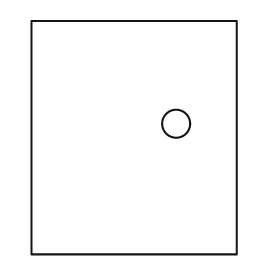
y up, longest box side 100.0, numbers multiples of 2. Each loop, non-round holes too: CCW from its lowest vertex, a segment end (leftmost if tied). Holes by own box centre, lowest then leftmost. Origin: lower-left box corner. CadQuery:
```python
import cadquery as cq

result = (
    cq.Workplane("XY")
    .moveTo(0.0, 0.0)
    .lineTo(88.0, 0.0)
    .lineTo(88.0, 100.0)
    .lineTo(0.0, 100.0)
    .close()
    .moveTo(62.0, 56.0)
    .circle(6.0)
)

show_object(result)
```